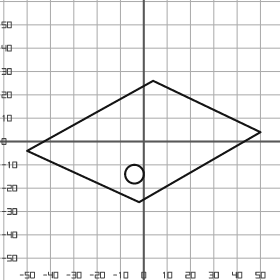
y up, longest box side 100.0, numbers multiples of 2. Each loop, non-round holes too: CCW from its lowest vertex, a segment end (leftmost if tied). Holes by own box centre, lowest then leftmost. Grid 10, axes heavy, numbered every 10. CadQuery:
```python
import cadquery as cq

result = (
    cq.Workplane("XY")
    .moveTo(-2.0, -26.0)
    .lineTo(50.0, 4.0)
    .lineTo(4.0, 26.0)
    .lineTo(-50.0, -4.0)
    .close()
    .moveTo(-4.0, -14.0)
    .circle(4.0)
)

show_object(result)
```